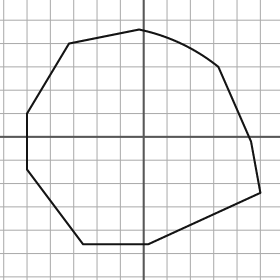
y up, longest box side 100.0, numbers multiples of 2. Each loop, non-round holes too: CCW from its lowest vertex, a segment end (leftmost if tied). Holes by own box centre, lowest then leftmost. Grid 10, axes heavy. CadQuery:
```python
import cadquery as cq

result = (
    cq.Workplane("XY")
    .moveTo(-26.0, -46.0)
    .lineTo(2.0, -46.0)
    .lineTo(50.0, -24.0)
    .lineTo(46.0, -2.0)
    .lineTo(32.0, 30.0)
    .threePointArc((16.0, 40.0), (-2.0, 46.0))
    .lineTo(-32.0, 40.0)
    .lineTo(-50.0, 10.0)
    .lineTo(-50.0, -14.0)
    .close()
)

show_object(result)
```